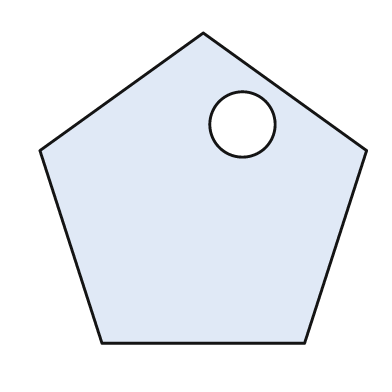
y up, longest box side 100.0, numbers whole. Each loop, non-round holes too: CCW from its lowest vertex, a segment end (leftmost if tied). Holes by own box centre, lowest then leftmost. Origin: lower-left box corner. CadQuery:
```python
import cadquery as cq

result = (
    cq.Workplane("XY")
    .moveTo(19.0, 0.0)
    .lineTo(81.0, 0.0)
    .lineTo(100.0, 59.0)
    .lineTo(50.0, 95.0)
    .lineTo(0.0, 59.0)
    .close()
    .moveTo(62.0, 67.0)
    .circle(10.0)
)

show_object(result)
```